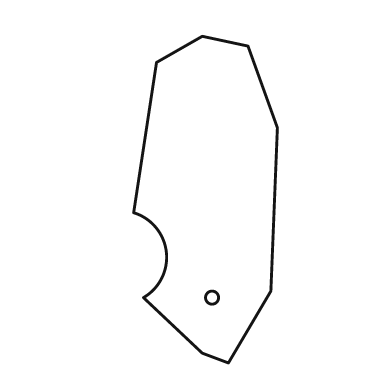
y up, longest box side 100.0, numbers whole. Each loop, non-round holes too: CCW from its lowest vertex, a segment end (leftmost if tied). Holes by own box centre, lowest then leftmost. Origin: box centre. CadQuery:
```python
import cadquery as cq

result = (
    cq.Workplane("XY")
    .moveTo(7.0, -50.0)
    .lineTo(20.0, -28.0)
    .lineTo(22.0, 22.0)
    .lineTo(13.0, 47.0)
    .lineTo(-1.0, 50.0)
    .lineTo(-15.0, 42.0)
    .lineTo(-22.0, -4.0)
    .threePointArc((-12.0, -16.0), (-19.0, -30.0))
    .lineTo(-1.0, -47.0)
    .close()
    .moveTo(2.0, -30.0)
    .circle(2.0)
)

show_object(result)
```